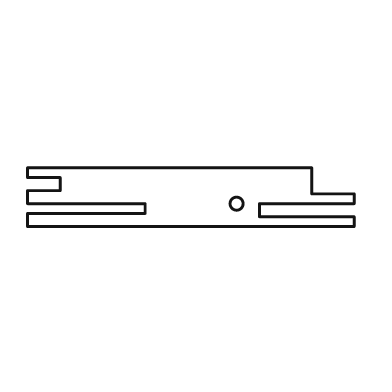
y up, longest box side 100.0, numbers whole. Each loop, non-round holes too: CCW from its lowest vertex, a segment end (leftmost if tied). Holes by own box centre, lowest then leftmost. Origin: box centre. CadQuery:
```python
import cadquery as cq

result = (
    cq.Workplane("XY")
    .moveTo(-50.0, -9.0)
    .lineTo(50.0, -9.0)
    .lineTo(50.0, -6.0)
    .lineTo(21.0, -6.0)
    .lineTo(21.0, -2.0)
    .lineTo(50.0, -2.0)
    .lineTo(50.0, 1.0)
    .lineTo(37.0, 1.0)
    .lineTo(37.0, 9.0)
    .lineTo(-50.0, 9.0)
    .lineTo(-50.0, 6.0)
    .lineTo(-40.0, 6.0)
    .lineTo(-40.0, 2.0)
    .lineTo(-50.0, 2.0)
    .lineTo(-50.0, -2.0)
    .lineTo(-14.0, -2.0)
    .lineTo(-14.0, -5.0)
    .lineTo(-50.0, -5.0)
    .close()
    .moveTo(14.0, -2.0)
    .circle(2.0)
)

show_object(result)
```